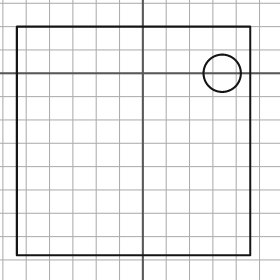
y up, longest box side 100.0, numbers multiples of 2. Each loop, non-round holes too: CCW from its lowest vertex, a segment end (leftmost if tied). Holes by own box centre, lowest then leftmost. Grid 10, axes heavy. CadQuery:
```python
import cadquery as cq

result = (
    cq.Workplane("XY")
    .moveTo(-54.0, -78.0)
    .lineTo(46.0, -78.0)
    .lineTo(46.0, 20.0)
    .lineTo(-54.0, 20.0)
    .close()
    .moveTo(34.0, 0.0)
    .circle(8.0)
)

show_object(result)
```